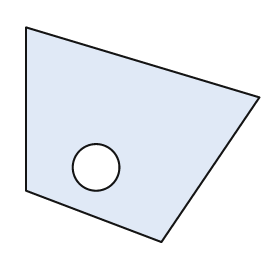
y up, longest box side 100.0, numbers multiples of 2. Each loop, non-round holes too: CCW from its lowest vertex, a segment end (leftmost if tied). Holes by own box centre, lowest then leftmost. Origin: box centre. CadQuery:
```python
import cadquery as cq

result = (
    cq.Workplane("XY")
    .moveTo(8.0, -46.0)
    .lineTo(50.0, 16.0)
    .lineTo(-50.0, 46.0)
    .lineTo(-50.0, -24.0)
    .close()
    .moveTo(-20.0, -14.0)
    .circle(10.0)
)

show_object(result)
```